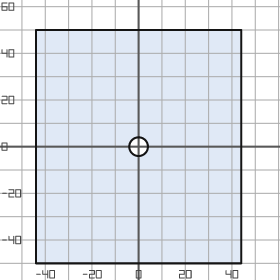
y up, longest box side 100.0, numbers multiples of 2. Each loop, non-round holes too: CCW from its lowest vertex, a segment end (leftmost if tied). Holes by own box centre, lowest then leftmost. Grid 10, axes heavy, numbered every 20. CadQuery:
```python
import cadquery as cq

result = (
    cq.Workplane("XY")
    .moveTo(-44.0, -50.0)
    .lineTo(44.0, -50.0)
    .lineTo(44.0, 50.0)
    .lineTo(-44.0, 50.0)
    .close()
    .moveTo(0.0, 0.0)
    .circle(4.0)
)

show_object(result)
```